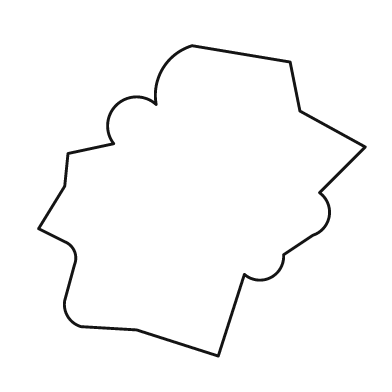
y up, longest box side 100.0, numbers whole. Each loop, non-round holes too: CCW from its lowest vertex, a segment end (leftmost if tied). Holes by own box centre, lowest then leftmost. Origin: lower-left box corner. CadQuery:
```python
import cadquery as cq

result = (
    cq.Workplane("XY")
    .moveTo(55.0, 0.0)
    .lineTo(63.0, 25.0)
    .threePointArc((71.0, 24.0), (75.0, 31.0))
    .lineTo(84.0, 37.0)
    .threePointArc((89.0, 43.0), (86.0, 50.0))
    .lineTo(100.0, 64.0)
    .lineTo(80.0, 75.0)
    .lineTo(77.0, 90.0)
    .lineTo(47.0, 95.0)
    .threePointArc((38.0, 88.0), (36.0, 77.0))
    .threePointArc((24.0, 77.0), (23.0, 65.0))
    .lineTo(9.0, 62.0)
    .lineTo(8.0, 52.0)
    .lineTo(0.0, 39.0)
    .lineTo(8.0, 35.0)
    .threePointArc((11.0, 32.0), (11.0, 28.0))
    .lineTo(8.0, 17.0)
    .threePointArc((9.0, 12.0), (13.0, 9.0))
    .lineTo(30.0, 8.0)
    .close()
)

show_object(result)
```